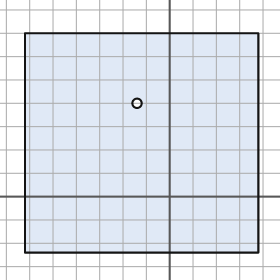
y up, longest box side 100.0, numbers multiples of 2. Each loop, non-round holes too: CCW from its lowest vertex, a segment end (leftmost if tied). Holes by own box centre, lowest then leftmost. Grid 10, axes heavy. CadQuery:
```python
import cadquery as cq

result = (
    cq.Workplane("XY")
    .moveTo(-62.0, -24.0)
    .lineTo(38.0, -24.0)
    .lineTo(38.0, 70.0)
    .lineTo(-62.0, 70.0)
    .close()
    .moveTo(-14.0, 40.0)
    .circle(2.0)
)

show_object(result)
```